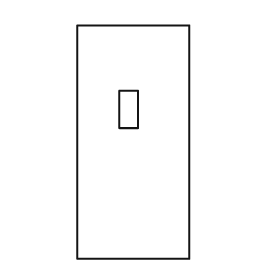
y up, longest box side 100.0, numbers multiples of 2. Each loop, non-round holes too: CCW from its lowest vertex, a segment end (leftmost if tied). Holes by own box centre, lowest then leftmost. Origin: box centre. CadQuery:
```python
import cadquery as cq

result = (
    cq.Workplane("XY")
    .moveTo(-24.0, -50.0)
    .lineTo(24.0, -50.0)
    .lineTo(24.0, 50.0)
    .lineTo(-24.0, 50.0)
    .close()
    .moveTo(-6.0, 6.0)
    .lineTo(2.0, 6.0)
    .lineTo(2.0, 22.0)
    .lineTo(-6.0, 22.0)
    .close()
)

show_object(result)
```